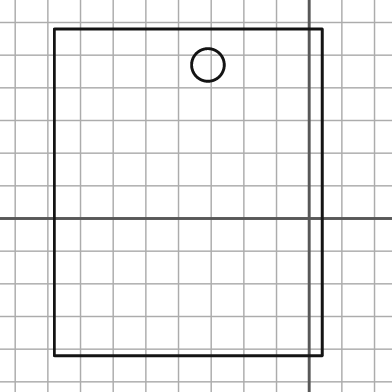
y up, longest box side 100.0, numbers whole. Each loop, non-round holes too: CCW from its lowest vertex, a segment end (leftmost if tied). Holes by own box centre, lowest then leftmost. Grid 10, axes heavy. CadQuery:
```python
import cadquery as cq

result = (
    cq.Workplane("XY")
    .moveTo(-78.0, -42.0)
    .lineTo(4.0, -42.0)
    .lineTo(4.0, 58.0)
    .lineTo(-78.0, 58.0)
    .close()
    .moveTo(-31.0, 47.0)
    .circle(5.0)
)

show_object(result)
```